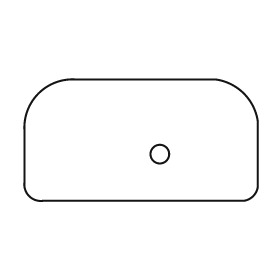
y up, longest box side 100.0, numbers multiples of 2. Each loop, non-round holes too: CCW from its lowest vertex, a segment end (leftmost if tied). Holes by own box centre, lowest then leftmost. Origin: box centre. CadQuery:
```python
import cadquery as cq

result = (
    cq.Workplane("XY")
    .moveTo(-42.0, -26.0)
    .lineTo(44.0, -26.0)
    .threePointArc((48.0, -24.0), (50.0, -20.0))
    .lineTo(50.0, 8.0)
    .threePointArc((44.0, 20.0), (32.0, 26.0))
    .lineTo(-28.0, 26.0)
    .threePointArc((-44.0, 20.0), (-50.0, 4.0))
    .lineTo(-50.0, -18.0)
    .threePointArc((-48.0, -24.0), (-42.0, -26.0))
    .close()
    .moveTo(8.0, -6.0)
    .circle(4.0)
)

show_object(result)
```